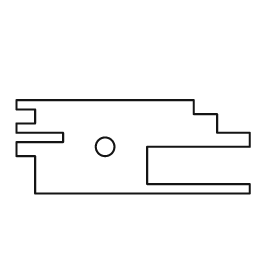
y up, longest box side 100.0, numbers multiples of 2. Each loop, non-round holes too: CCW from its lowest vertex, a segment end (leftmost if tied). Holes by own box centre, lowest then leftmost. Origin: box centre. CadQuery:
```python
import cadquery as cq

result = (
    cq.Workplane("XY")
    .moveTo(-42.0, -20.0)
    .lineTo(50.0, -20.0)
    .lineTo(50.0, -16.0)
    .lineTo(6.0, -16.0)
    .lineTo(6.0, 0.0)
    .lineTo(50.0, 0.0)
    .lineTo(50.0, 6.0)
    .lineTo(36.0, 6.0)
    .lineTo(36.0, 14.0)
    .lineTo(26.0, 14.0)
    .lineTo(26.0, 20.0)
    .lineTo(-50.0, 20.0)
    .lineTo(-50.0, 16.0)
    .lineTo(-42.0, 16.0)
    .lineTo(-42.0, 10.0)
    .lineTo(-50.0, 10.0)
    .lineTo(-50.0, 6.0)
    .lineTo(-30.0, 6.0)
    .lineTo(-30.0, 2.0)
    .lineTo(-50.0, 2.0)
    .lineTo(-50.0, -4.0)
    .lineTo(-42.0, -4.0)
    .close()
    .moveTo(-12.0, 0.0)
    .circle(4.0)
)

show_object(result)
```